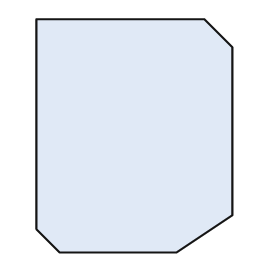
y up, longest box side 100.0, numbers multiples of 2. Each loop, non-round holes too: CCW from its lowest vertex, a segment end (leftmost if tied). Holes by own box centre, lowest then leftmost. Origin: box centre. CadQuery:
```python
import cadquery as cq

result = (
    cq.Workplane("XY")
    .moveTo(-32.0, -50.0)
    .lineTo(18.0, -50.0)
    .lineTo(42.0, -34.0)
    .lineTo(42.0, 38.0)
    .lineTo(30.0, 50.0)
    .lineTo(-42.0, 50.0)
    .lineTo(-42.0, -40.0)
    .close()
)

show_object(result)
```